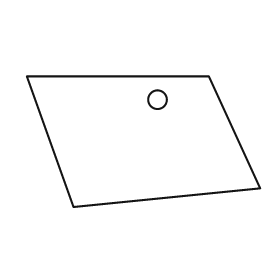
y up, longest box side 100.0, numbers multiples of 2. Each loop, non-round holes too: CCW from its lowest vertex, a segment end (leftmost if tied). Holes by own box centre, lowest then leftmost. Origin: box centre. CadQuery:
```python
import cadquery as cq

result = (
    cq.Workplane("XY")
    .moveTo(-30.0, -28.0)
    .lineTo(50.0, -20.0)
    .lineTo(28.0, 28.0)
    .lineTo(-50.0, 28.0)
    .close()
    .moveTo(6.0, 18.0)
    .circle(4.0)
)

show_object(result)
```